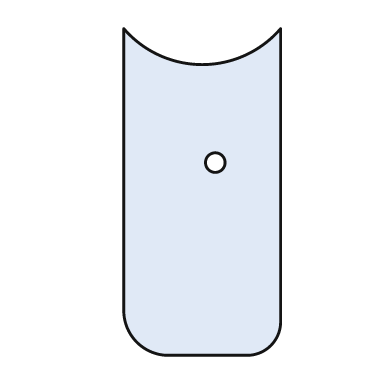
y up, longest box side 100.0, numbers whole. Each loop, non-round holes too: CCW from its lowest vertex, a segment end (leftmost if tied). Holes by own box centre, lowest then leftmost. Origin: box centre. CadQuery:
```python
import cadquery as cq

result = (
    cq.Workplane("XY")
    .moveTo(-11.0, -50.0)
    .lineTo(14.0, -50.0)
    .threePointArc((21.0, -47.0), (24.0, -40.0))
    .lineTo(24.0, 50.0)
    .threePointArc((0.0, 39.0), (-24.0, 50.0))
    .lineTo(-24.0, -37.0)
    .threePointArc((-20.0, -46.0), (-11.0, -50.0))
    .close()
    .moveTo(4.0, 9.0)
    .circle(3.0)
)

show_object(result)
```